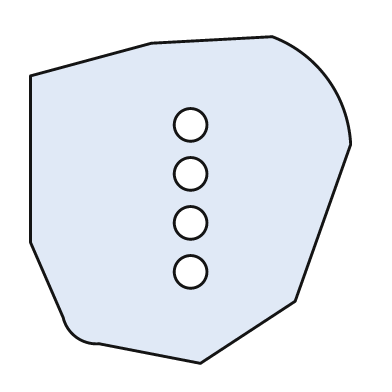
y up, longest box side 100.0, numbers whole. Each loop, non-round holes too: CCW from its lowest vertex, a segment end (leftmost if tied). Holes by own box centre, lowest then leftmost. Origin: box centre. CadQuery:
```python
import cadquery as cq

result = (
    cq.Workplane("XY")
    .moveTo(3.0, -50.0)
    .lineTo(32.0, -31.0)
    .lineTo(49.0, 17.0)
    .threePointArc((42.0, 37.0), (25.0, 50.0))
    .lineTo(-12.0, 48.0)
    .lineTo(-49.0, 38.0)
    .lineTo(-49.0, -13.0)
    .lineTo(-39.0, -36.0)
    .threePointArc((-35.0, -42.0), (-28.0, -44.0))
    .close()
    .moveTo(0.0, -22.0)
    .circle(5.0)
    .moveTo(0.0, -7.0)
    .circle(5.0)
    .moveTo(0.0, 8.0)
    .circle(5.0)
    .moveTo(0.0, 23.0)
    .circle(5.0)
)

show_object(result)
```